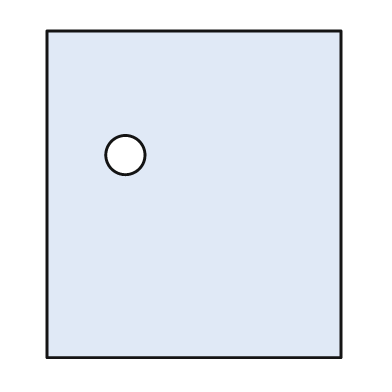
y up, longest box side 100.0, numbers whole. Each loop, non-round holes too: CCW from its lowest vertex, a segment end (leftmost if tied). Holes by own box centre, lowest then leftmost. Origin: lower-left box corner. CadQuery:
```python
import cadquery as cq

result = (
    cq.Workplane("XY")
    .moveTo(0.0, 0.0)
    .lineTo(90.0, 0.0)
    .lineTo(90.0, 100.0)
    .lineTo(0.0, 100.0)
    .close()
    .moveTo(24.0, 62.0)
    .circle(6.0)
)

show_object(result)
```